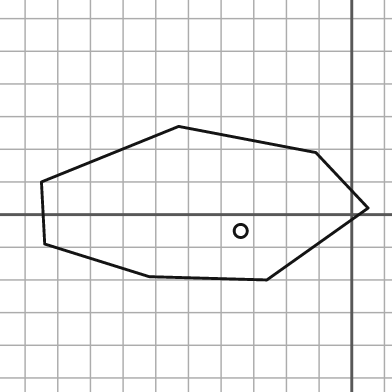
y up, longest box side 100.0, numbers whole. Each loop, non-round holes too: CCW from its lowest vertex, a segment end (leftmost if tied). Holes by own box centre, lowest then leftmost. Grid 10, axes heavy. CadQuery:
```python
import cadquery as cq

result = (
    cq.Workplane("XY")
    .moveTo(-26.0, -20.0)
    .lineTo(5.0, 2.0)
    .lineTo(-11.0, 19.0)
    .lineTo(-53.0, 27.0)
    .lineTo(-95.0, 10.0)
    .lineTo(-94.0, -9.0)
    .lineTo(-62.0, -19.0)
    .close()
    .moveTo(-34.0, -5.0)
    .circle(2.0)
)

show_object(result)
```